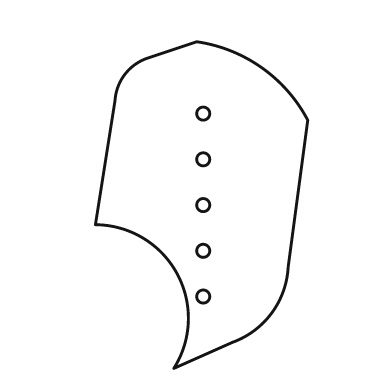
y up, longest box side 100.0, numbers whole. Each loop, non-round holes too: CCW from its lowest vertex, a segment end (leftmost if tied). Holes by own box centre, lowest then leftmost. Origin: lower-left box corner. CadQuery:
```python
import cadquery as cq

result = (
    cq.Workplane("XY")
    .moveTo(24.0, 0.0)
    .lineTo(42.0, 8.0)
    .threePointArc((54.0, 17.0), (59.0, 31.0))
    .lineTo(65.0, 76.0)
    .threePointArc((51.0, 92.0), (31.0, 100.0))
    .lineTo(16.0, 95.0)
    .threePointArc((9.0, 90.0), (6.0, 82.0))
    .lineTo(0.0, 44.0)
    .threePointArc((25.0, 29.0), (24.0, 0.0))
    .close()
    .moveTo(33.0, 22.0)
    .circle(2.0)
    .moveTo(33.0, 36.0)
    .circle(2.0)
    .moveTo(33.0, 50.0)
    .circle(2.0)
    .moveTo(33.0, 64.0)
    .circle(2.0)
    .moveTo(33.0, 78.0)
    .circle(2.0)
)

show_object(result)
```